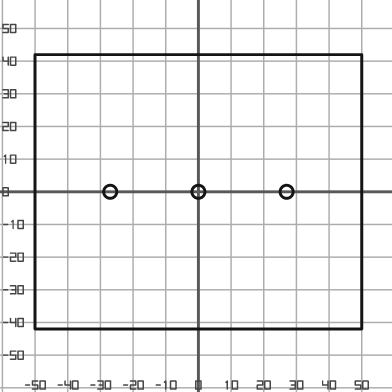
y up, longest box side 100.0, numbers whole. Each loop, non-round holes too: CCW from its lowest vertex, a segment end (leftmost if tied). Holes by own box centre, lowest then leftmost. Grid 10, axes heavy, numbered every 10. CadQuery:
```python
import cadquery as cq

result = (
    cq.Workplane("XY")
    .moveTo(-50.0, -42.0)
    .lineTo(50.0, -42.0)
    .lineTo(50.0, 42.0)
    .lineTo(-50.0, 42.0)
    .close()
    .moveTo(-27.0, 0.0)
    .circle(2.0)
    .moveTo(0.0, 0.0)
    .circle(2.0)
    .moveTo(27.0, 0.0)
    .circle(2.0)
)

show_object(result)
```